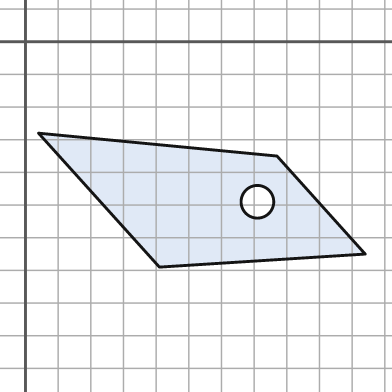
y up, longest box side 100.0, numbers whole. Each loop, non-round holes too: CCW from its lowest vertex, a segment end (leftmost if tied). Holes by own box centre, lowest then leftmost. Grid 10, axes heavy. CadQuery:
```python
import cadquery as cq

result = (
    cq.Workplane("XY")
    .moveTo(41.0, -69.0)
    .lineTo(104.0, -65.0)
    .lineTo(77.0, -35.0)
    .lineTo(4.0, -28.0)
    .close()
    .moveTo(71.0, -49.0)
    .circle(5.0)
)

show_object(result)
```